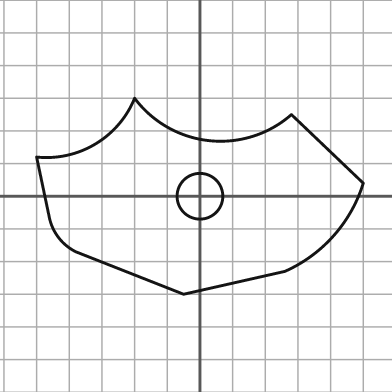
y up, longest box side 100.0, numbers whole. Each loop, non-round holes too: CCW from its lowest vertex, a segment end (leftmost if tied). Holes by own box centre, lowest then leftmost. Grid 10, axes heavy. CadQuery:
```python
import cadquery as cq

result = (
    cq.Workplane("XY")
    .moveTo(-5.0, -30.0)
    .lineTo(26.0, -23.0)
    .threePointArc((41.0, -12.0), (50.0, 4.0))
    .lineTo(28.0, 25.0)
    .threePointArc((3.0, 17.0), (-20.0, 30.0))
    .threePointArc((-32.0, 16.0), (-50.0, 12.0))
    .lineTo(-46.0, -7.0)
    .threePointArc((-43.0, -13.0), (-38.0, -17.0))
    .close()
    .moveTo(0.0, 0.0)
    .circle(7.0)
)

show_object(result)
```